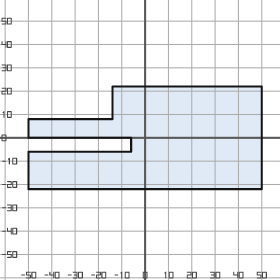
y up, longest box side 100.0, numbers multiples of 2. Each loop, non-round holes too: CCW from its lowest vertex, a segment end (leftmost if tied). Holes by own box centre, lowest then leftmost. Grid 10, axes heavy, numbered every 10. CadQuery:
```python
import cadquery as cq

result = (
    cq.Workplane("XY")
    .moveTo(-50.0, -22.0)
    .lineTo(50.0, -22.0)
    .lineTo(50.0, 22.0)
    .lineTo(-14.0, 22.0)
    .lineTo(-14.0, 8.0)
    .lineTo(-50.0, 8.0)
    .lineTo(-50.0, 0.0)
    .lineTo(-6.0, 0.0)
    .lineTo(-6.0, -6.0)
    .lineTo(-50.0, -6.0)
    .close()
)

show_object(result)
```